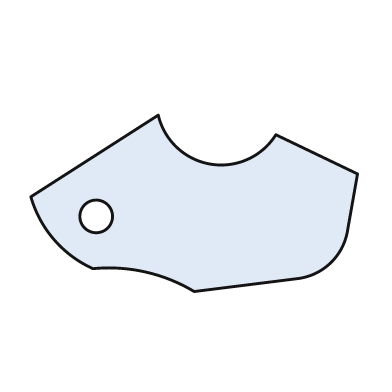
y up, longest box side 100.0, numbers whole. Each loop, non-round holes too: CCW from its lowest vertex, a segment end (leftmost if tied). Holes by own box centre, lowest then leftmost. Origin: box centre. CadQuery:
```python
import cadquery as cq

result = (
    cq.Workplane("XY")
    .moveTo(0.0, -27.0)
    .lineTo(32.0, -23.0)
    .threePointArc((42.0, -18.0), (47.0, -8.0))
    .lineTo(50.0, 9.0)
    .lineTo(25.0, 21.0)
    .threePointArc((5.0, 12.0), (-11.0, 27.0))
    .lineTo(-50.0, 2.0)
    .threePointArc((-43.0, -11.0), (-31.0, -20.0))
    .threePointArc((-15.0, -21.0), (0.0, -27.0))
    .close()
    .moveTo(-30.0, -4.0)
    .circle(5.0)
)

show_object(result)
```